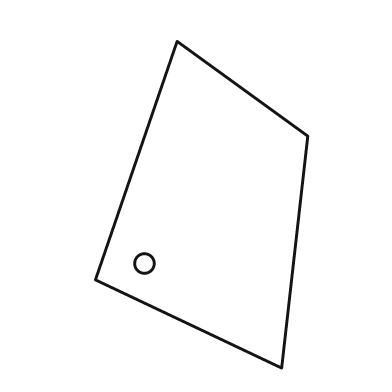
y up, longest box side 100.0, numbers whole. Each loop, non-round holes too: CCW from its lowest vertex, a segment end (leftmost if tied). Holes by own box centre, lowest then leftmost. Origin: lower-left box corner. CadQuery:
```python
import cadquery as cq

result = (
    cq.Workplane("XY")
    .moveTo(57.0, 0.0)
    .lineTo(65.0, 71.0)
    .lineTo(25.0, 100.0)
    .lineTo(0.0, 27.0)
    .close()
    .moveTo(15.0, 32.0)
    .circle(3.0)
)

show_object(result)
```